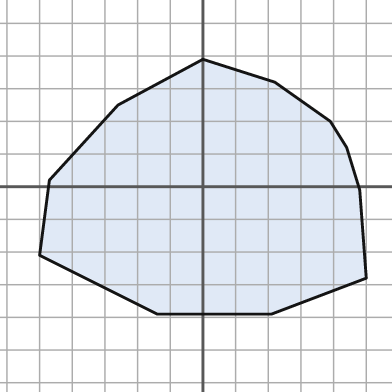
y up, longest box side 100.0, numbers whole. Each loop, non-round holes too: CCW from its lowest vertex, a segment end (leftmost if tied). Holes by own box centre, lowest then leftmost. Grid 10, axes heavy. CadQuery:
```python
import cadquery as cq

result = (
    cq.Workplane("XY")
    .moveTo(-14.0, -39.0)
    .lineTo(21.0, -39.0)
    .lineTo(50.0, -28.0)
    .lineTo(48.0, -1.0)
    .lineTo(44.0, 12.0)
    .lineTo(39.0, 20.0)
    .lineTo(22.0, 32.0)
    .lineTo(0.0, 39.0)
    .lineTo(-26.0, 25.0)
    .lineTo(-47.0, 2.0)
    .lineTo(-50.0, -21.0)
    .close()
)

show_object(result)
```